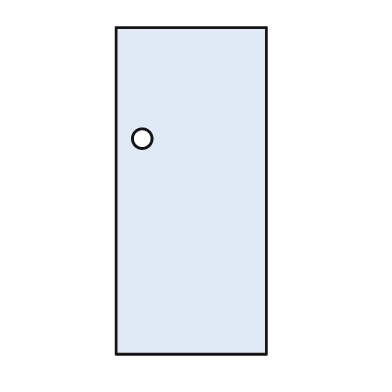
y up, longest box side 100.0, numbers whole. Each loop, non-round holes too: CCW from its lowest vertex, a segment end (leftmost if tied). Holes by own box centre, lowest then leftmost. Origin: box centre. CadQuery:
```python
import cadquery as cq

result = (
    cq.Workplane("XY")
    .moveTo(-23.0, -50.0)
    .lineTo(23.0, -50.0)
    .lineTo(23.0, 50.0)
    .lineTo(-23.0, 50.0)
    .close()
    .moveTo(-15.0, 16.0)
    .circle(3.0)
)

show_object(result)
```